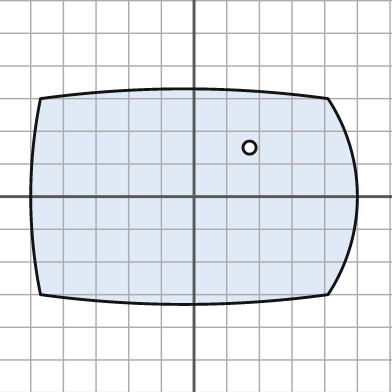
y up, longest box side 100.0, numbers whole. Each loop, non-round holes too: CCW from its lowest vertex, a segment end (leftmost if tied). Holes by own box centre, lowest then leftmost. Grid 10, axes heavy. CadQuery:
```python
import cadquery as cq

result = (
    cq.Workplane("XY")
    .moveTo(-47.0, -30.0)
    .threePointArc((-3.0, -33.0), (41.0, -30.0))
    .threePointArc((50.0, 0.0), (41.0, 30.0))
    .threePointArc((-3.0, 33.0), (-47.0, 30.0))
    .threePointArc((-50.0, 0.0), (-47.0, -30.0))
    .close()
    .moveTo(17.0, 15.0)
    .circle(2.0)
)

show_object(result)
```